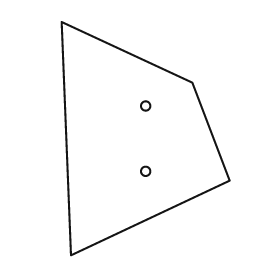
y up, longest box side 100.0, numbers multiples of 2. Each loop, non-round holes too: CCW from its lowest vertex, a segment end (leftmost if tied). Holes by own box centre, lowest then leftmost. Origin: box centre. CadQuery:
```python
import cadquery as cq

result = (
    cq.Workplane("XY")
    .moveTo(-32.0, -50.0)
    .lineTo(36.0, -18.0)
    .lineTo(20.0, 24.0)
    .lineTo(-36.0, 50.0)
    .close()
    .moveTo(0.0, -14.0)
    .circle(2.0)
    .moveTo(0.0, 14.0)
    .circle(2.0)
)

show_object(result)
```